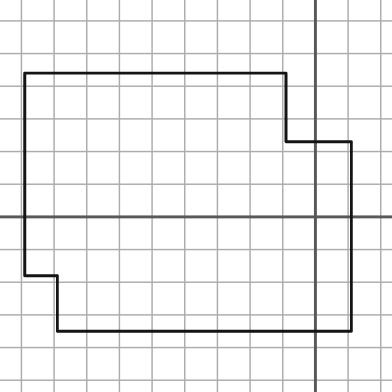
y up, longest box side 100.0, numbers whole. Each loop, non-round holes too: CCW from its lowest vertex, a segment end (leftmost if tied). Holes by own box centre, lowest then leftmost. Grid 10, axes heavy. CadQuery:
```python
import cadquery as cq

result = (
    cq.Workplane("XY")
    .moveTo(-79.0, -35.0)
    .lineTo(11.0, -35.0)
    .lineTo(11.0, 23.0)
    .lineTo(-9.0, 23.0)
    .lineTo(-9.0, 44.0)
    .lineTo(-89.0, 44.0)
    .lineTo(-89.0, -18.0)
    .lineTo(-79.0, -18.0)
    .close()
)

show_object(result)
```